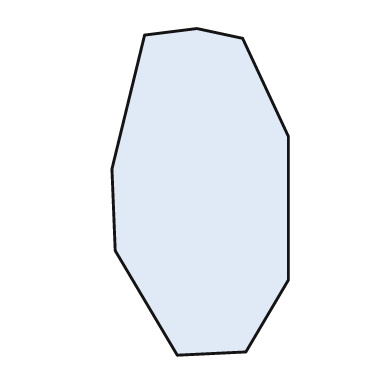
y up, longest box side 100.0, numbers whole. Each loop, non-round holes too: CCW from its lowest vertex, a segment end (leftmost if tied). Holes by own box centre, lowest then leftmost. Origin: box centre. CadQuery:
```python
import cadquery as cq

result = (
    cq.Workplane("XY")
    .moveTo(-7.0, -50.0)
    .lineTo(14.0, -49.0)
    .lineTo(27.0, -27.0)
    .lineTo(27.0, 17.0)
    .lineTo(13.0, 47.0)
    .lineTo(-1.0, 50.0)
    .lineTo(-17.0, 48.0)
    .lineTo(-27.0, 7.0)
    .lineTo(-26.0, -18.0)
    .close()
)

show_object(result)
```